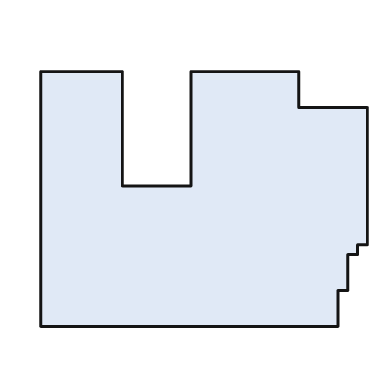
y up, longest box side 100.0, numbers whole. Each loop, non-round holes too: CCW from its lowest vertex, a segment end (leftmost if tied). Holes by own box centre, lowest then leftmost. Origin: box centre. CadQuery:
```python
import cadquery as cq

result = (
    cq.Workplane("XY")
    .moveTo(-50.0, -39.0)
    .lineTo(41.0, -39.0)
    .lineTo(41.0, -28.0)
    .lineTo(44.0, -28.0)
    .lineTo(44.0, -17.0)
    .lineTo(47.0, -17.0)
    .lineTo(47.0, -14.0)
    .lineTo(50.0, -14.0)
    .lineTo(50.0, 28.0)
    .lineTo(29.0, 28.0)
    .lineTo(29.0, 39.0)
    .lineTo(-4.0, 39.0)
    .lineTo(-4.0, 4.0)
    .lineTo(-25.0, 4.0)
    .lineTo(-25.0, 39.0)
    .lineTo(-50.0, 39.0)
    .close()
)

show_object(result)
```